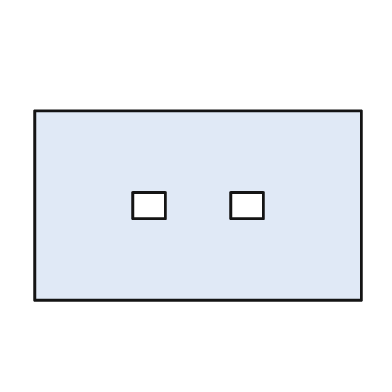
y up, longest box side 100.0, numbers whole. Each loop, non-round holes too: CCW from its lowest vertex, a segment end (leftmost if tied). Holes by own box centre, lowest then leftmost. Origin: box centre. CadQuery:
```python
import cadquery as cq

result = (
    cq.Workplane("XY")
    .moveTo(-50.0, -29.0)
    .lineTo(50.0, -29.0)
    .lineTo(50.0, 29.0)
    .lineTo(-50.0, 29.0)
    .close()
    .moveTo(-20.0, -4.0)
    .lineTo(-10.0, -4.0)
    .lineTo(-10.0, 4.0)
    .lineTo(-20.0, 4.0)
    .close()
    .moveTo(10.0, -4.0)
    .lineTo(20.0, -4.0)
    .lineTo(20.0, 4.0)
    .lineTo(10.0, 4.0)
    .close()
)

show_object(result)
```